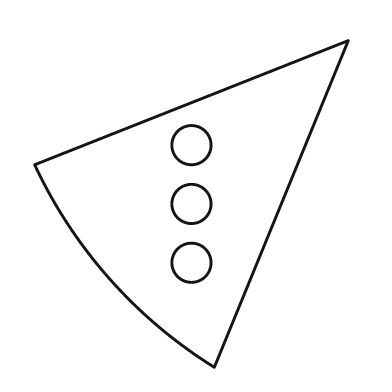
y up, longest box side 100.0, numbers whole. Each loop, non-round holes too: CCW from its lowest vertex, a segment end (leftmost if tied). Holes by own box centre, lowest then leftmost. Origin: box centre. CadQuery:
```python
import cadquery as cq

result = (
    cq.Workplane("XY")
    .moveTo(7.0, -50.0)
    .lineTo(48.0, 50.0)
    .lineTo(-48.0, 12.0)
    .threePointArc((-25.0, -23.0), (7.0, -50.0))
    .close()
    .moveTo(0.0, -18.0)
    .circle(6.0)
    .moveTo(0.0, 0.0)
    .circle(6.0)
    .moveTo(0.0, 18.0)
    .circle(6.0)
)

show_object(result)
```